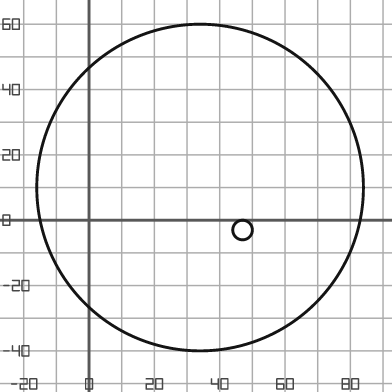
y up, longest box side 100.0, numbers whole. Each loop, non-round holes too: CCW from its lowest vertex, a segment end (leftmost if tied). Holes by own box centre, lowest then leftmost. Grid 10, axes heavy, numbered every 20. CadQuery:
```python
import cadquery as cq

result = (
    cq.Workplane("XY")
    .moveTo(34.0, 10.0)
    .circle(50.0)
    .moveTo(47.0, -3.0)
    .circle(3.0)
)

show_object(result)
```